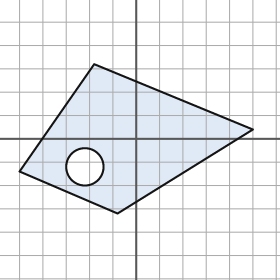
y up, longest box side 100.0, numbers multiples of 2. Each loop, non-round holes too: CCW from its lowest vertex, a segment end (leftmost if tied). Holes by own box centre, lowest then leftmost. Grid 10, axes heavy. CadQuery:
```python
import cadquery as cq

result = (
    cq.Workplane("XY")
    .moveTo(-8.0, -32.0)
    .lineTo(50.0, 4.0)
    .lineTo(-18.0, 32.0)
    .lineTo(-50.0, -14.0)
    .close()
    .moveTo(-22.0, -12.0)
    .circle(8.0)
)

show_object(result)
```